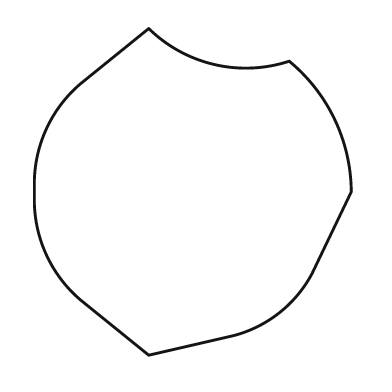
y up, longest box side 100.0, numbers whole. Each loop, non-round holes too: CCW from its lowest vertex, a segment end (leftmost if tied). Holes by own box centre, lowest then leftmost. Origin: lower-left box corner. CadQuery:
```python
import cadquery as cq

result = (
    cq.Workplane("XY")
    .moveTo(35.0, 0.0)
    .lineTo(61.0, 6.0)
    .threePointArc((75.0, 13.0), (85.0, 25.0))
    .lineTo(97.0, 50.0)
    .threePointArc((92.0, 72.0), (78.0, 90.0))
    .threePointArc((55.0, 89.0), (35.0, 100.0))
    .lineTo(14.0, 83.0)
    .threePointArc((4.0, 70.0), (0.0, 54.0))
    .lineTo(0.0, 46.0)
    .threePointArc((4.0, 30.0), (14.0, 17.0))
    .close()
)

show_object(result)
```